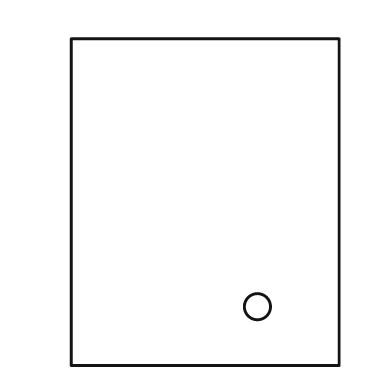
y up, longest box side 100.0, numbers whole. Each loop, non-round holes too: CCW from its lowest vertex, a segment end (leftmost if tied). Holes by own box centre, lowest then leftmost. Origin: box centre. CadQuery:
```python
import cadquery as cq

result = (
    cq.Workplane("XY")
    .moveTo(-41.0, -50.0)
    .lineTo(41.0, -50.0)
    .lineTo(41.0, 50.0)
    .lineTo(-41.0, 50.0)
    .close()
    .moveTo(16.0, -32.0)
    .circle(4.0)
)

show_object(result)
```